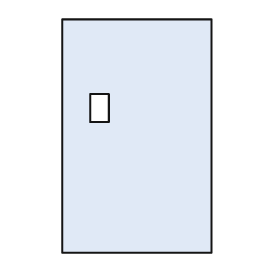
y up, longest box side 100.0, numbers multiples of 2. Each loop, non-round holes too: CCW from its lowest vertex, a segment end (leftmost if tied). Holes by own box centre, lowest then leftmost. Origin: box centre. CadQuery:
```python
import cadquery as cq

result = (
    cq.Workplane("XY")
    .moveTo(-32.0, -50.0)
    .lineTo(32.0, -50.0)
    .lineTo(32.0, 50.0)
    .lineTo(-32.0, 50.0)
    .close()
    .moveTo(-20.0, 6.0)
    .lineTo(-12.0, 6.0)
    .lineTo(-12.0, 18.0)
    .lineTo(-20.0, 18.0)
    .close()
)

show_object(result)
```